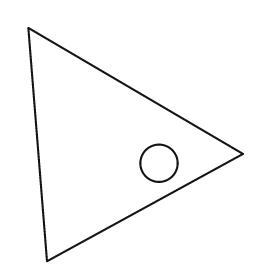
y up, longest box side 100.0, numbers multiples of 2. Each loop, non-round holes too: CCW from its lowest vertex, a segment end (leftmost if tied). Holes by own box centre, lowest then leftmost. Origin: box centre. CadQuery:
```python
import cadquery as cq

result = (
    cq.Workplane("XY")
    .moveTo(-38.0, -50.0)
    .lineTo(46.0, -4.0)
    .lineTo(-46.0, 50.0)
    .close()
    .moveTo(10.0, -8.0)
    .circle(8.0)
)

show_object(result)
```